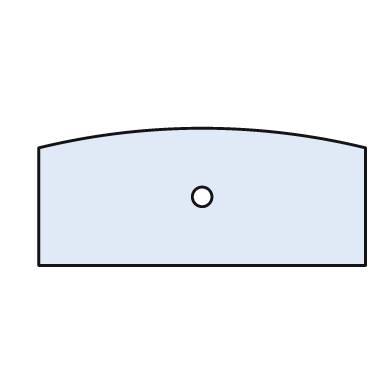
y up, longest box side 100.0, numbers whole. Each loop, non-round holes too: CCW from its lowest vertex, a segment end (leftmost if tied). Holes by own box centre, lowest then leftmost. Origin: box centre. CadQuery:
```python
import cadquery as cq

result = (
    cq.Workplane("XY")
    .moveTo(-50.0, -21.0)
    .lineTo(50.0, -21.0)
    .lineTo(50.0, 15.0)
    .threePointArc((0.0, 21.0), (-50.0, 15.0))
    .close()
    .moveTo(0.0, 0.0)
    .circle(3.0)
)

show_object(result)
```